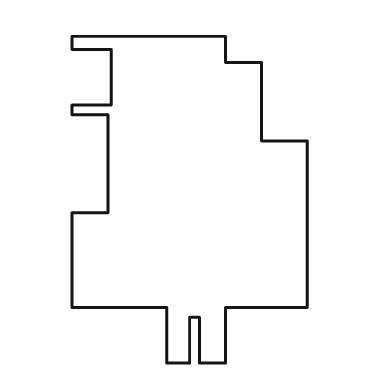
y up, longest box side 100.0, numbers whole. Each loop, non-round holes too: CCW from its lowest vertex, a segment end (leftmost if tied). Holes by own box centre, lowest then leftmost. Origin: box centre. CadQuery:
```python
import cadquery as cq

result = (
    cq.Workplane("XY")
    .moveTo(-7.0, -50.0)
    .lineTo(0.0, -50.0)
    .lineTo(0.0, -36.0)
    .lineTo(3.0, -36.0)
    .lineTo(3.0, -50.0)
    .lineTo(11.0, -50.0)
    .lineTo(11.0, -33.0)
    .lineTo(36.0, -33.0)
    .lineTo(36.0, 18.0)
    .lineTo(22.0, 18.0)
    .lineTo(22.0, 42.0)
    .lineTo(11.0, 42.0)
    .lineTo(11.0, 50.0)
    .lineTo(-36.0, 50.0)
    .lineTo(-36.0, 46.0)
    .lineTo(-24.0, 46.0)
    .lineTo(-24.0, 29.0)
    .lineTo(-36.0, 29.0)
    .lineTo(-36.0, 26.0)
    .lineTo(-25.0, 26.0)
    .lineTo(-25.0, -4.0)
    .lineTo(-36.0, -4.0)
    .lineTo(-36.0, -33.0)
    .lineTo(-7.0, -33.0)
    .close()
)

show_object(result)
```